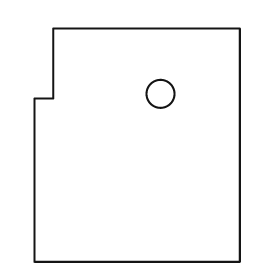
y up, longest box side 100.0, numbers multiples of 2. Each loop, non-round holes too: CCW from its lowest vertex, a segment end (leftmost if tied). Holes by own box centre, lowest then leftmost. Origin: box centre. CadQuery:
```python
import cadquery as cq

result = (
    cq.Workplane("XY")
    .moveTo(-44.0, -50.0)
    .lineTo(44.0, -50.0)
    .lineTo(44.0, 50.0)
    .lineTo(-36.0, 50.0)
    .lineTo(-36.0, 20.0)
    .lineTo(-44.0, 20.0)
    .close()
    .moveTo(10.0, 22.0)
    .circle(6.0)
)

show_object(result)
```